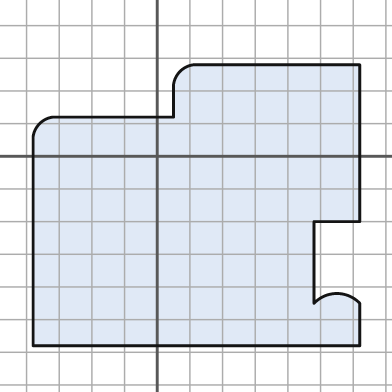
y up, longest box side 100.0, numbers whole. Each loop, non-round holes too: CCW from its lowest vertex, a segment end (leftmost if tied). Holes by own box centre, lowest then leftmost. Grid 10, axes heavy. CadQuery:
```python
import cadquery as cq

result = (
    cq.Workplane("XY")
    .moveTo(-38.0, -58.0)
    .lineTo(62.0, -58.0)
    .lineTo(62.0, -45.0)
    .threePointArc((55.0, -42.0), (48.0, -45.0))
    .lineTo(48.0, -20.0)
    .lineTo(62.0, -20.0)
    .lineTo(62.0, 28.0)
    .lineTo(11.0, 28.0)
    .threePointArc((7.0, 26.0), (5.0, 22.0))
    .lineTo(5.0, 12.0)
    .lineTo(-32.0, 12.0)
    .threePointArc((-36.0, 10.0), (-38.0, 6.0))
    .close()
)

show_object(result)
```